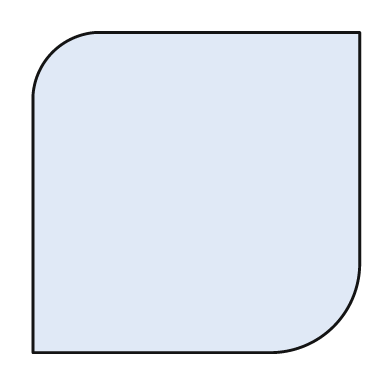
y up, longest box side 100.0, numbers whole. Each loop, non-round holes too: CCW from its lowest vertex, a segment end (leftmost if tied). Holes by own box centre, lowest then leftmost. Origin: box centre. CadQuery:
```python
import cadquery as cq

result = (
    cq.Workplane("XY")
    .moveTo(-50.0, -49.0)
    .lineTo(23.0, -49.0)
    .threePointArc((42.0, -41.0), (50.0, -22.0))
    .lineTo(50.0, 49.0)
    .lineTo(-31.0, 49.0)
    .threePointArc((-44.0, 43.0), (-50.0, 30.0))
    .close()
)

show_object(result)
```